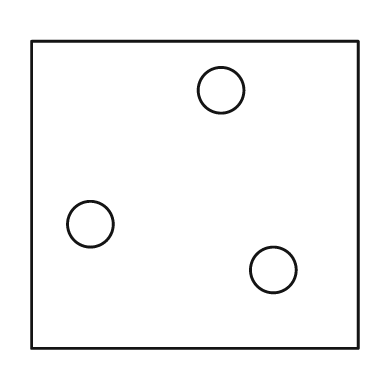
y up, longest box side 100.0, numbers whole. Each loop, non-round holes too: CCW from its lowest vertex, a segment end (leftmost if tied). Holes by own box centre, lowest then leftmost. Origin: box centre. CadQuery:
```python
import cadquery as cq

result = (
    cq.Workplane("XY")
    .moveTo(-50.0, -47.0)
    .lineTo(50.0, -47.0)
    .lineTo(50.0, 47.0)
    .lineTo(-50.0, 47.0)
    .close()
    .moveTo(24.0, -23.0)
    .circle(7.0)
    .moveTo(-32.0, -9.0)
    .circle(7.0)
    .moveTo(8.0, 32.0)
    .circle(7.0)
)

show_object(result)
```